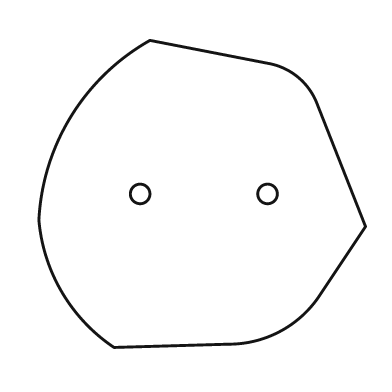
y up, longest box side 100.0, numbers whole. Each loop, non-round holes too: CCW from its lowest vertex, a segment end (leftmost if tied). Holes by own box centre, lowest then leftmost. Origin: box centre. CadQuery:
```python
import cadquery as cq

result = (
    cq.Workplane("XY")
    .moveTo(-27.0, -47.0)
    .lineTo(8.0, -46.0)
    .threePointArc((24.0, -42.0), (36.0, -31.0))
    .lineTo(50.0, -10.0)
    .lineTo(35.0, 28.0)
    .threePointArc((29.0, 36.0), (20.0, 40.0))
    .lineTo(-16.0, 47.0)
    .threePointArc((-40.0, 24.0), (-50.0, -8.0))
    .threePointArc((-43.0, -30.0), (-27.0, -47.0))
    .close()
    .moveTo(-19.0, 0.0)
    .circle(3.0)
    .moveTo(20.0, 0.0)
    .circle(3.0)
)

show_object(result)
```